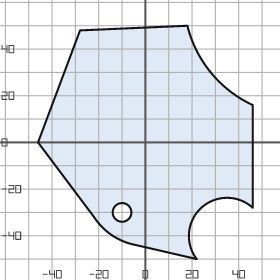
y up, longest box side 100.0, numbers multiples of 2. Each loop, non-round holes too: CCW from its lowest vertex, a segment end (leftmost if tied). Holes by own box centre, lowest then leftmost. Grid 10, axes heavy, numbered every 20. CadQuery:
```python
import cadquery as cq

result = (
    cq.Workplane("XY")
    .moveTo(22.0, -50.0)
    .threePointArc((24.0, -28.0), (46.0, -28.0))
    .lineTo(46.0, 16.0)
    .threePointArc((28.0, 30.0), (18.0, 50.0))
    .lineTo(-28.0, 48.0)
    .lineTo(-46.0, 0.0)
    .lineTo(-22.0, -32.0)
    .threePointArc((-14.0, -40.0), (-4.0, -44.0))
    .close()
    .moveTo(-10.0, -30.0)
    .circle(4.0)
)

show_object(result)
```